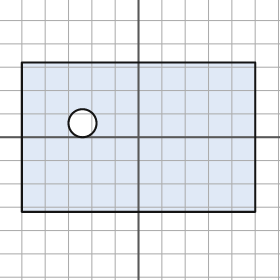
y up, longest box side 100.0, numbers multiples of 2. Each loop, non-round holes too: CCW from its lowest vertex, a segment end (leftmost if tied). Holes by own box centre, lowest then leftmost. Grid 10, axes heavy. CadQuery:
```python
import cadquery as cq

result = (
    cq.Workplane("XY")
    .moveTo(-50.0, -32.0)
    .lineTo(50.0, -32.0)
    .lineTo(50.0, 32.0)
    .lineTo(-50.0, 32.0)
    .close()
    .moveTo(-24.0, 6.0)
    .circle(6.0)
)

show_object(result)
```